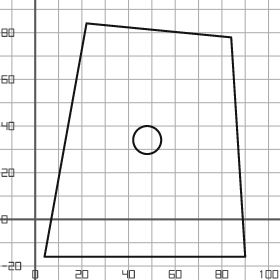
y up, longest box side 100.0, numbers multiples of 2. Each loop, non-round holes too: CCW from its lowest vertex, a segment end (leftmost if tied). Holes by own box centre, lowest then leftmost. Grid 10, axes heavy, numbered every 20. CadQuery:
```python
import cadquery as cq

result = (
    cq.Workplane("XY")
    .moveTo(4.0, -16.0)
    .lineTo(90.0, -16.0)
    .lineTo(84.0, 78.0)
    .lineTo(22.0, 84.0)
    .close()
    .moveTo(48.0, 34.0)
    .circle(6.0)
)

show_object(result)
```